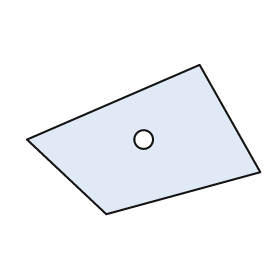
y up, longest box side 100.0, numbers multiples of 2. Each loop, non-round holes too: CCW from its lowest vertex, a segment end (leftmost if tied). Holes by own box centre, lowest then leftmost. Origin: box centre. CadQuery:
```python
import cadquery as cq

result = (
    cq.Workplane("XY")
    .moveTo(-16.0, -32.0)
    .lineTo(50.0, -14.0)
    .lineTo(24.0, 32.0)
    .lineTo(-50.0, 0.0)
    .close()
    .moveTo(0.0, 0.0)
    .circle(4.0)
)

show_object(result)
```